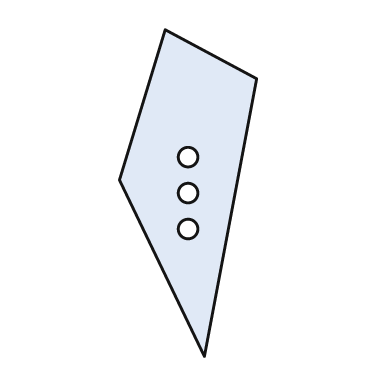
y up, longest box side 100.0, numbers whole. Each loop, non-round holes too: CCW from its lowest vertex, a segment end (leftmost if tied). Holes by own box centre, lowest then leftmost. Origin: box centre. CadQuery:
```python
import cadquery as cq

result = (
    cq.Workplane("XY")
    .moveTo(5.0, -50.0)
    .lineTo(21.0, 35.0)
    .lineTo(-7.0, 50.0)
    .lineTo(-21.0, 4.0)
    .close()
    .moveTo(0.0, -11.0)
    .circle(3.0)
    .moveTo(0.0, 0.0)
    .circle(3.0)
    .moveTo(0.0, 11.0)
    .circle(3.0)
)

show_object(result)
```